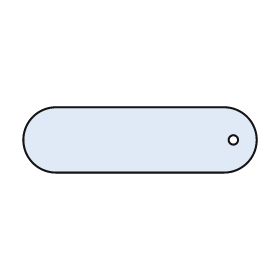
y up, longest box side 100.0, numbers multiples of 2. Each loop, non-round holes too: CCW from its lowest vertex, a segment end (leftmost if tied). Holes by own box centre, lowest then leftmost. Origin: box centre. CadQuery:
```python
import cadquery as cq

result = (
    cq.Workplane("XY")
    .moveTo(-36.0, -14.0)
    .lineTo(36.0, -14.0)
    .threePointArc((50.0, 0.0), (36.0, 14.0))
    .lineTo(-36.0, 14.0)
    .threePointArc((-50.0, 0.0), (-36.0, -14.0))
    .close()
    .moveTo(40.0, 0.0)
    .circle(2.0)
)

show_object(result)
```